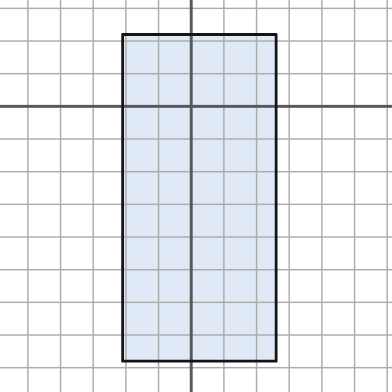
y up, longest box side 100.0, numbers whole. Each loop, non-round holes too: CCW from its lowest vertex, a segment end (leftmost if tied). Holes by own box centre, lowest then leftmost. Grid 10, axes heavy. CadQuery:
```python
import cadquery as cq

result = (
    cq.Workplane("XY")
    .moveTo(-21.0, -78.0)
    .lineTo(26.0, -78.0)
    .lineTo(26.0, 22.0)
    .lineTo(-21.0, 22.0)
    .close()
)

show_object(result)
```